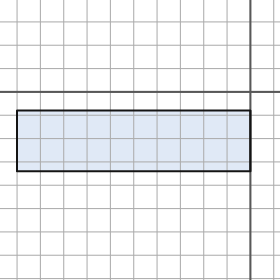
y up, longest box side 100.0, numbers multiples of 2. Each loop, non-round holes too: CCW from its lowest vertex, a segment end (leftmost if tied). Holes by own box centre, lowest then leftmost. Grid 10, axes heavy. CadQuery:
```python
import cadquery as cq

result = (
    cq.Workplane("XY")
    .moveTo(-100.0, -34.0)
    .lineTo(0.0, -34.0)
    .lineTo(0.0, -8.0)
    .lineTo(-100.0, -8.0)
    .close()
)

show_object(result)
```